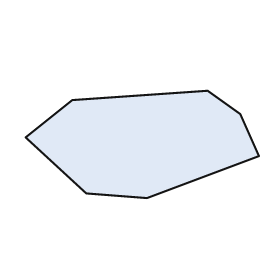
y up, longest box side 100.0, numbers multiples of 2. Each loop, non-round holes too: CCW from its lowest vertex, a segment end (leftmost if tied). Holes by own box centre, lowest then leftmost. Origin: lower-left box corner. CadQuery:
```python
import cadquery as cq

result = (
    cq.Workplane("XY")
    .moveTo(52.0, 0.0)
    .lineTo(100.0, 18.0)
    .lineTo(92.0, 36.0)
    .lineTo(78.0, 46.0)
    .lineTo(20.0, 42.0)
    .lineTo(0.0, 26.0)
    .lineTo(26.0, 2.0)
    .close()
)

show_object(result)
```